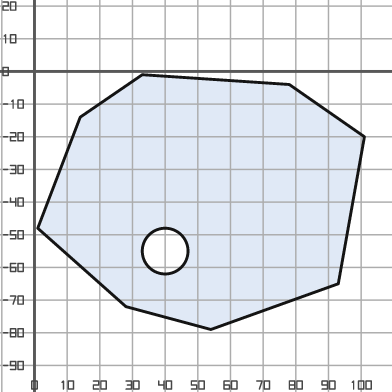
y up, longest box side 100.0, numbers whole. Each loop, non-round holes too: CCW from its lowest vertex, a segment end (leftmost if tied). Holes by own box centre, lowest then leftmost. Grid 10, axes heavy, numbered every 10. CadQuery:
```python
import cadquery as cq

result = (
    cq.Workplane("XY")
    .moveTo(54.0, -79.0)
    .lineTo(93.0, -65.0)
    .lineTo(101.0, -20.0)
    .lineTo(78.0, -4.0)
    .lineTo(33.0, -1.0)
    .lineTo(14.0, -14.0)
    .lineTo(1.0, -48.0)
    .lineTo(28.0, -72.0)
    .close()
    .moveTo(40.0, -55.0)
    .circle(7.0)
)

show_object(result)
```